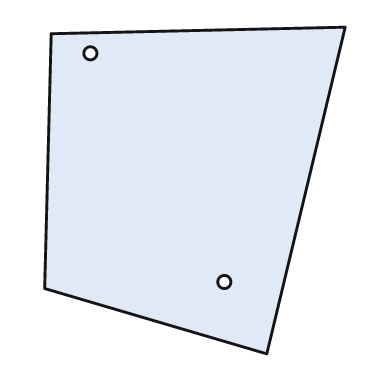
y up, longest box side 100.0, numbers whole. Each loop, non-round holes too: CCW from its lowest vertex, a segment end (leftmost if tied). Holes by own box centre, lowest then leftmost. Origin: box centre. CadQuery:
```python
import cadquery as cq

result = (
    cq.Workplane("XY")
    .moveTo(22.0, -50.0)
    .lineTo(46.0, 50.0)
    .lineTo(-44.0, 48.0)
    .lineTo(-46.0, -30.0)
    .close()
    .moveTo(9.0, -28.0)
    .circle(2.0)
    .moveTo(-32.0, 42.0)
    .circle(2.0)
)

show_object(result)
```